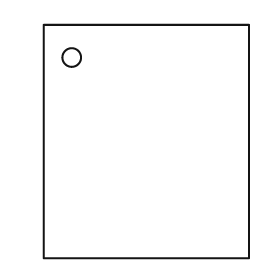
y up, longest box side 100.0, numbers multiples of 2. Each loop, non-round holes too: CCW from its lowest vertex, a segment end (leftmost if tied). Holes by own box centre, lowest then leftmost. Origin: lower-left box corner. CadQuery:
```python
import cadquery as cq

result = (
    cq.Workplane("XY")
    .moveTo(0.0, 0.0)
    .lineTo(88.0, 0.0)
    .lineTo(88.0, 100.0)
    .lineTo(0.0, 100.0)
    .close()
    .moveTo(12.0, 86.0)
    .circle(4.0)
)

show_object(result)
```